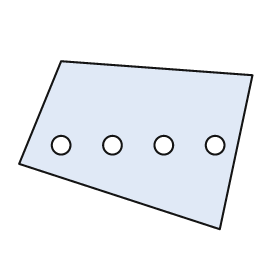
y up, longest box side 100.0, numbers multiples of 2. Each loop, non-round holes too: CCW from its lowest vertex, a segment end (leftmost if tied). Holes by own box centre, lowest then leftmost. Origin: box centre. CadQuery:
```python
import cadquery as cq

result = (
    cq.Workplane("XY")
    .moveTo(36.0, -36.0)
    .lineTo(50.0, 30.0)
    .lineTo(-32.0, 36.0)
    .lineTo(-50.0, -8.0)
    .close()
    .moveTo(-32.0, 0.0)
    .circle(4.0)
    .moveTo(-10.0, 0.0)
    .circle(4.0)
    .moveTo(12.0, 0.0)
    .circle(4.0)
    .moveTo(34.0, 0.0)
    .circle(4.0)
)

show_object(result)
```